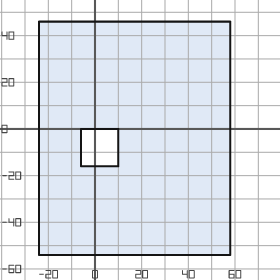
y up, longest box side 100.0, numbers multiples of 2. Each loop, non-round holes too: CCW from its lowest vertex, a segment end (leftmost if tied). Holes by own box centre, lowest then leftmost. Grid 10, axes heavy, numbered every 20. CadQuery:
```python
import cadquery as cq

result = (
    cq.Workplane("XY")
    .moveTo(-24.0, -54.0)
    .lineTo(58.0, -54.0)
    .lineTo(58.0, 46.0)
    .lineTo(-24.0, 46.0)
    .close()
    .moveTo(-6.0, -16.0)
    .lineTo(10.0, -16.0)
    .lineTo(10.0, 0.0)
    .lineTo(-6.0, 0.0)
    .close()
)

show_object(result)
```